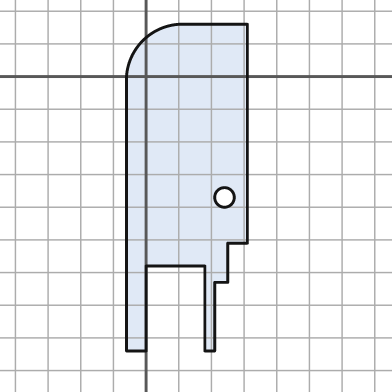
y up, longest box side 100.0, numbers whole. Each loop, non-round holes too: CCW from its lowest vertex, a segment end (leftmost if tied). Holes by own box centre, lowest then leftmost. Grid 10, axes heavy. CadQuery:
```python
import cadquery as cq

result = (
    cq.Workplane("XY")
    .moveTo(-6.0, -84.0)
    .lineTo(0.0, -84.0)
    .lineTo(0.0, -58.0)
    .lineTo(18.0, -58.0)
    .lineTo(18.0, -84.0)
    .lineTo(21.0, -84.0)
    .lineTo(21.0, -63.0)
    .lineTo(25.0, -63.0)
    .lineTo(25.0, -51.0)
    .lineTo(31.0, -51.0)
    .lineTo(31.0, 16.0)
    .lineTo(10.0, 16.0)
    .threePointArc((-1.0, 11.0), (-6.0, 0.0))
    .close()
    .moveTo(24.0, -37.0)
    .circle(3.0)
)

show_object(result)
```